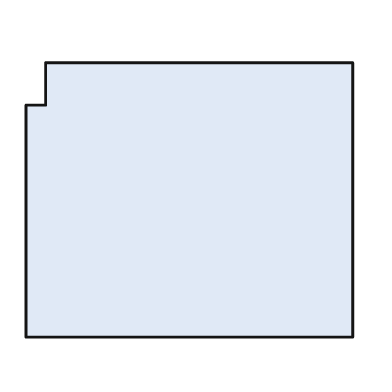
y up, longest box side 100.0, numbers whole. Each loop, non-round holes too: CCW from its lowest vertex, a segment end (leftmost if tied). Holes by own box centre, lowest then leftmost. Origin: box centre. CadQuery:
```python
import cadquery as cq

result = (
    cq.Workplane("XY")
    .moveTo(-50.0, -42.0)
    .lineTo(50.0, -42.0)
    .lineTo(50.0, 42.0)
    .lineTo(-44.0, 42.0)
    .lineTo(-44.0, 29.0)
    .lineTo(-50.0, 29.0)
    .close()
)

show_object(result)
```